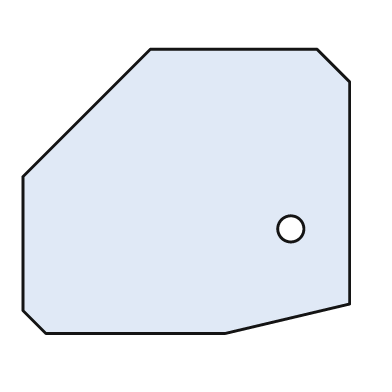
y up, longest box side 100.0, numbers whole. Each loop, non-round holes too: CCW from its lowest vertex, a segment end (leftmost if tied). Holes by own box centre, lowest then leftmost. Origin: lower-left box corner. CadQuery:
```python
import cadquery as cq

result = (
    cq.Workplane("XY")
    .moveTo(7.0, 0.0)
    .lineTo(62.0, 0.0)
    .lineTo(100.0, 9.0)
    .lineTo(100.0, 77.0)
    .lineTo(90.0, 87.0)
    .lineTo(39.0, 87.0)
    .lineTo(0.0, 48.0)
    .lineTo(0.0, 7.0)
    .close()
    .moveTo(82.0, 32.0)
    .circle(4.0)
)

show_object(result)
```